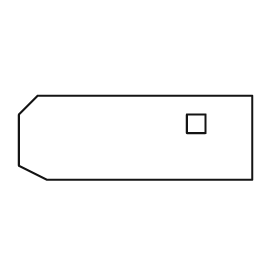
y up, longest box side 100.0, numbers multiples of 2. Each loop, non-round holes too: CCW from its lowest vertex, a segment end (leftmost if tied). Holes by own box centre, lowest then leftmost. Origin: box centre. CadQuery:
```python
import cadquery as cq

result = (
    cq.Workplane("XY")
    .moveTo(-38.0, -18.0)
    .lineTo(50.0, -18.0)
    .lineTo(50.0, 18.0)
    .lineTo(-42.0, 18.0)
    .lineTo(-50.0, 10.0)
    .lineTo(-50.0, -12.0)
    .close()
    .moveTo(22.0, 2.0)
    .lineTo(30.0, 2.0)
    .lineTo(30.0, 10.0)
    .lineTo(22.0, 10.0)
    .close()
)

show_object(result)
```